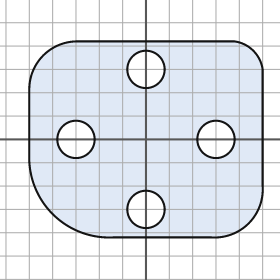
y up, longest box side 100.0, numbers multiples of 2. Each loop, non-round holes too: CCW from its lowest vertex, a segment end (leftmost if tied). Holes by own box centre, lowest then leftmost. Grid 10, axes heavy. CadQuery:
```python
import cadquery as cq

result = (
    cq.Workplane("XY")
    .moveTo(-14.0, -42.0)
    .lineTo(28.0, -42.0)
    .threePointArc((44.0, -36.0), (50.0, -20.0))
    .lineTo(50.0, 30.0)
    .threePointArc((46.0, 38.0), (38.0, 42.0))
    .lineTo(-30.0, 42.0)
    .threePointArc((-44.0, 36.0), (-50.0, 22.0))
    .lineTo(-50.0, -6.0)
    .threePointArc((-40.0, -32.0), (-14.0, -42.0))
    .close()
    .moveTo(0.0, -30.0)
    .circle(8.0)
    .moveTo(-30.0, 0.0)
    .circle(8.0)
    .moveTo(30.0, 0.0)
    .circle(8.0)
    .moveTo(0.0, 30.0)
    .circle(8.0)
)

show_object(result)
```